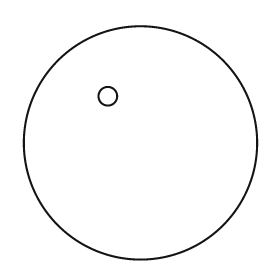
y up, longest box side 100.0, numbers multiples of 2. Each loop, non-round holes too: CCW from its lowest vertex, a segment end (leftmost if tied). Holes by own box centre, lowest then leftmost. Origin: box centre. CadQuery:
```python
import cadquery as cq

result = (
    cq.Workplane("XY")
    .moveTo(0.0, 0.0)
    .circle(50.0)
    .moveTo(-14.0, 20.0)
    .circle(4.0)
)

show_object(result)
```